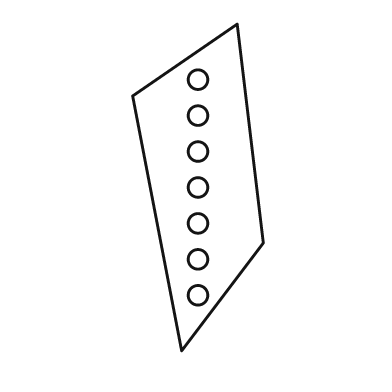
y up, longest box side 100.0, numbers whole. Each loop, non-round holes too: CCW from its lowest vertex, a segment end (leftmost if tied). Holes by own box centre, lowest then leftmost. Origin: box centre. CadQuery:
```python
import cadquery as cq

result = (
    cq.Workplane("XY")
    .moveTo(-5.0, -50.0)
    .lineTo(20.0, -17.0)
    .lineTo(12.0, 50.0)
    .lineTo(-20.0, 28.0)
    .close()
    .moveTo(0.0, -33.0)
    .circle(3.0)
    .moveTo(0.0, -22.0)
    .circle(3.0)
    .moveTo(0.0, -11.0)
    .circle(3.0)
    .moveTo(0.0, 0.0)
    .circle(3.0)
    .moveTo(0.0, 11.0)
    .circle(3.0)
    .moveTo(0.0, 22.0)
    .circle(3.0)
    .moveTo(0.0, 33.0)
    .circle(3.0)
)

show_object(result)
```